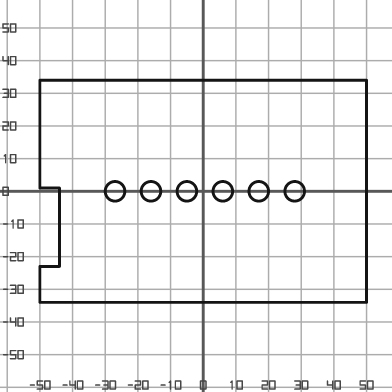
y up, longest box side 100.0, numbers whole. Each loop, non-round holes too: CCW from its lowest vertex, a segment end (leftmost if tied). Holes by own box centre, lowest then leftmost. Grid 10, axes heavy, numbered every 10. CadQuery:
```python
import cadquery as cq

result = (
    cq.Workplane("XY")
    .moveTo(-50.0, -34.0)
    .lineTo(50.0, -34.0)
    .lineTo(50.0, 34.0)
    .lineTo(-50.0, 34.0)
    .lineTo(-50.0, 1.0)
    .lineTo(-44.0, 1.0)
    .lineTo(-44.0, -23.0)
    .lineTo(-50.0, -23.0)
    .close()
    .moveTo(-27.0, 0.0)
    .circle(3.0)
    .moveTo(-16.0, 0.0)
    .circle(3.0)
    .moveTo(-5.0, 0.0)
    .circle(3.0)
    .moveTo(6.0, 0.0)
    .circle(3.0)
    .moveTo(17.0, 0.0)
    .circle(3.0)
    .moveTo(28.0, 0.0)
    .circle(3.0)
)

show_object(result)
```